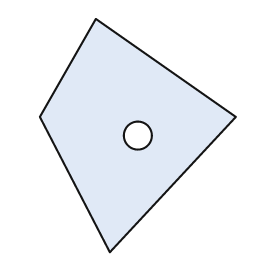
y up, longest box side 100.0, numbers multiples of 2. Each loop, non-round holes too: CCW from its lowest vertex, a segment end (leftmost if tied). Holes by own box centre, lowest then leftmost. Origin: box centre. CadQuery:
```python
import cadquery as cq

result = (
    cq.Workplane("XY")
    .moveTo(-12.0, -50.0)
    .lineTo(42.0, 8.0)
    .lineTo(-18.0, 50.0)
    .lineTo(-42.0, 8.0)
    .close()
    .moveTo(0.0, 0.0)
    .circle(6.0)
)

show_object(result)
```